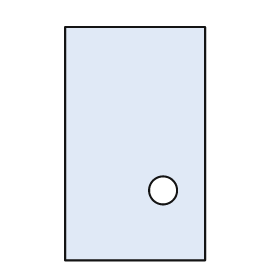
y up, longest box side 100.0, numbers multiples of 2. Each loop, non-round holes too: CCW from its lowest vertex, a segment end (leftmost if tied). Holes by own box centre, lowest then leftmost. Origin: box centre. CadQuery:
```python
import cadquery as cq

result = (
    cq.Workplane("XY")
    .moveTo(-30.0, -50.0)
    .lineTo(30.0, -50.0)
    .lineTo(30.0, 50.0)
    .lineTo(-30.0, 50.0)
    .close()
    .moveTo(12.0, -20.0)
    .circle(6.0)
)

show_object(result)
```